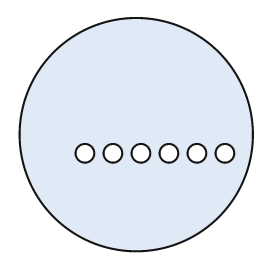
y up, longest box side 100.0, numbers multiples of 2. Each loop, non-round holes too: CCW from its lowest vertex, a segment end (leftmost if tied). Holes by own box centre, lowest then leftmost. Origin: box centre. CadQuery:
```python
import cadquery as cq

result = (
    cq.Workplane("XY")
    .moveTo(0.0, 0.0)
    .circle(50.0)
    .moveTo(-22.0, -8.0)
    .circle(4.0)
    .moveTo(-10.0, -8.0)
    .circle(4.0)
    .moveTo(2.0, -8.0)
    .circle(4.0)
    .moveTo(14.0, -8.0)
    .circle(4.0)
    .moveTo(26.0, -8.0)
    .circle(4.0)
    .moveTo(38.0, -8.0)
    .circle(4.0)
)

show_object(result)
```